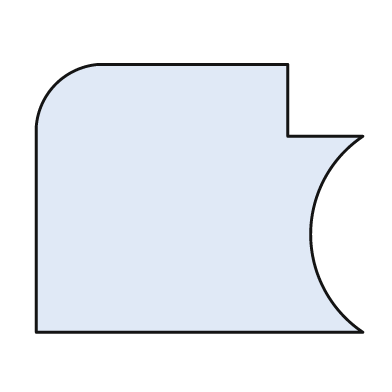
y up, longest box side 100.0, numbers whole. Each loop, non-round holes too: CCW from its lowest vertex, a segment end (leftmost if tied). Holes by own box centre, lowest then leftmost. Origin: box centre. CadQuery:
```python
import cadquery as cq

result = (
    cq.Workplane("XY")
    .moveTo(-50.0, -41.0)
    .lineTo(50.0, -41.0)
    .threePointArc((34.0, -11.0), (50.0, 19.0))
    .lineTo(27.0, 19.0)
    .lineTo(27.0, 41.0)
    .lineTo(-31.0, 41.0)
    .threePointArc((-44.0, 35.0), (-50.0, 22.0))
    .close()
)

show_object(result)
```